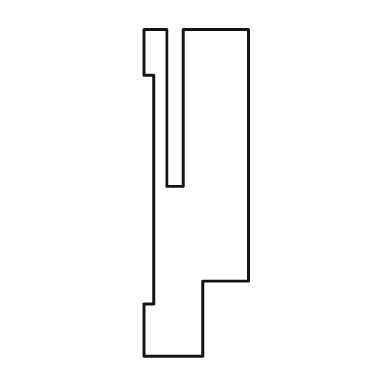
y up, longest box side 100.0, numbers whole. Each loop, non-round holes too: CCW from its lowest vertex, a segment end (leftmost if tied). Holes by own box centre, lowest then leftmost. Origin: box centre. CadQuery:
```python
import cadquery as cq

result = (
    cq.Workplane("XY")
    .moveTo(-16.0, -50.0)
    .lineTo(2.0, -50.0)
    .lineTo(2.0, -27.0)
    .lineTo(16.0, -27.0)
    .lineTo(16.0, 50.0)
    .lineTo(-4.0, 50.0)
    .lineTo(-4.0, 2.0)
    .lineTo(-9.0, 2.0)
    .lineTo(-9.0, 50.0)
    .lineTo(-16.0, 50.0)
    .lineTo(-16.0, 36.0)
    .lineTo(-13.0, 36.0)
    .lineTo(-13.0, -34.0)
    .lineTo(-16.0, -34.0)
    .close()
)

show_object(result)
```